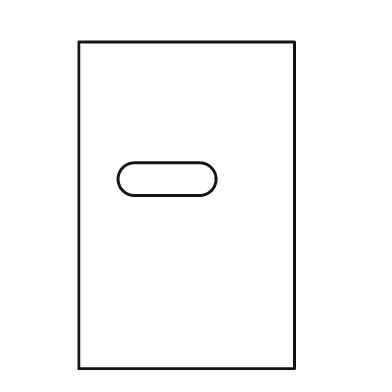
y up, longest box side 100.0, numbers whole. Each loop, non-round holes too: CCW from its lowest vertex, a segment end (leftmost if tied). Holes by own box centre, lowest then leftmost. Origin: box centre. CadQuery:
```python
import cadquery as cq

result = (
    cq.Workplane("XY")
    .moveTo(-33.0, -50.0)
    .lineTo(33.0, -50.0)
    .lineTo(33.0, 50.0)
    .lineTo(-33.0, 50.0)
    .close()
    .moveTo(-16.0, 3.0)
    .lineTo(4.0, 3.0)
    .threePointArc((9.0, 8.0), (4.0, 13.0))
    .lineTo(-16.0, 13.0)
    .threePointArc((-21.0, 8.0), (-16.0, 3.0))
    .close()
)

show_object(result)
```